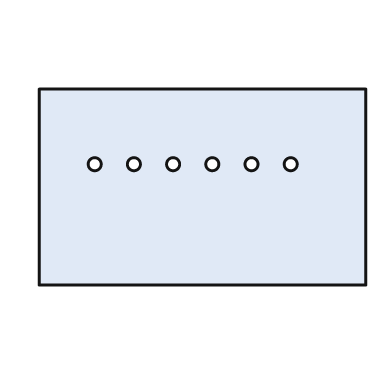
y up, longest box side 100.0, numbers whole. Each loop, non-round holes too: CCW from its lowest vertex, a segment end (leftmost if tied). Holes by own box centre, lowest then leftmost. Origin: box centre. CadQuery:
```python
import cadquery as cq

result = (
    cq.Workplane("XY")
    .moveTo(-50.0, -30.0)
    .lineTo(50.0, -30.0)
    .lineTo(50.0, 30.0)
    .lineTo(-50.0, 30.0)
    .close()
    .moveTo(-33.0, 7.0)
    .circle(2.0)
    .moveTo(-21.0, 7.0)
    .circle(2.0)
    .moveTo(-9.0, 7.0)
    .circle(2.0)
    .moveTo(3.0, 7.0)
    .circle(2.0)
    .moveTo(15.0, 7.0)
    .circle(2.0)
    .moveTo(27.0, 7.0)
    .circle(2.0)
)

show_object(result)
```